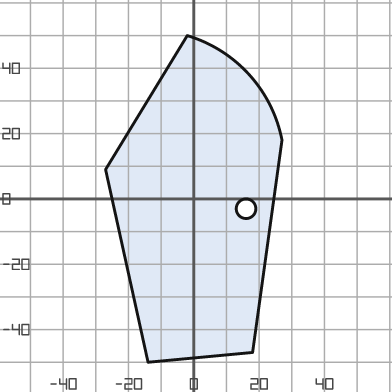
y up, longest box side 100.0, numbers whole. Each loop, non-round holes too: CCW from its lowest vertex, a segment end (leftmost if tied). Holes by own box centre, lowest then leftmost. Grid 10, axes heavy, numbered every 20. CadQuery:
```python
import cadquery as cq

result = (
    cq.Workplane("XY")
    .moveTo(-14.0, -50.0)
    .lineTo(18.0, -47.0)
    .lineTo(27.0, 18.0)
    .threePointArc((17.0, 38.0), (-2.0, 50.0))
    .lineTo(-27.0, 9.0)
    .close()
    .moveTo(16.0, -3.0)
    .circle(3.0)
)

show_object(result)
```